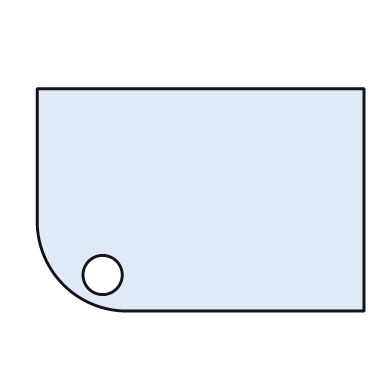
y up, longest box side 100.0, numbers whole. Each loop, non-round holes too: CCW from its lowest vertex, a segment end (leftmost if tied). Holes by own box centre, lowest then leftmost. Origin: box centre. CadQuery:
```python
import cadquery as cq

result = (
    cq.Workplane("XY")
    .moveTo(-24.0, -34.0)
    .lineTo(50.0, -34.0)
    .lineTo(50.0, 34.0)
    .lineTo(-50.0, 34.0)
    .lineTo(-50.0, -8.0)
    .threePointArc((-42.0, -26.0), (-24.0, -34.0))
    .close()
    .moveTo(-30.0, -23.0)
    .circle(6.0)
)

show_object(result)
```